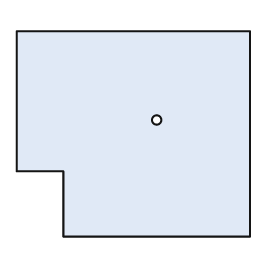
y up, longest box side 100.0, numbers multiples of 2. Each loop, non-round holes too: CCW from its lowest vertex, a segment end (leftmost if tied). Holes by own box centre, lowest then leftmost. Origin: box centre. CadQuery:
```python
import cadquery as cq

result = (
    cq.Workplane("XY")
    .moveTo(-30.0, -44.0)
    .lineTo(50.0, -44.0)
    .lineTo(50.0, 44.0)
    .lineTo(-50.0, 44.0)
    .lineTo(-50.0, -16.0)
    .lineTo(-30.0, -16.0)
    .close()
    .moveTo(10.0, 6.0)
    .circle(2.0)
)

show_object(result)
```